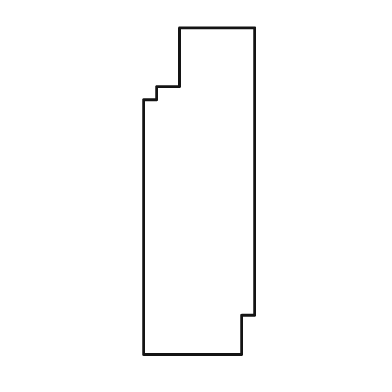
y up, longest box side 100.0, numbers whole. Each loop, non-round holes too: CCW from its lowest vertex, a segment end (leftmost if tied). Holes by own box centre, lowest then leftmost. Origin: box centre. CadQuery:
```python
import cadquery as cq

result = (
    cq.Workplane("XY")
    .moveTo(-17.0, -50.0)
    .lineTo(13.0, -50.0)
    .lineTo(13.0, -38.0)
    .lineTo(17.0, -38.0)
    .lineTo(17.0, 50.0)
    .lineTo(-6.0, 50.0)
    .lineTo(-6.0, 32.0)
    .lineTo(-13.0, 32.0)
    .lineTo(-13.0, 28.0)
    .lineTo(-17.0, 28.0)
    .close()
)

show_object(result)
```